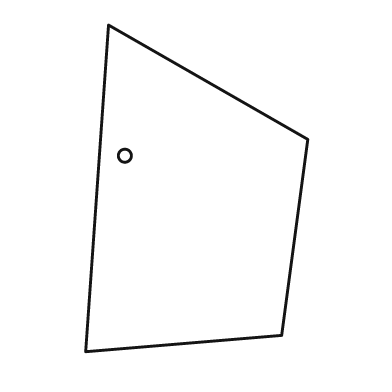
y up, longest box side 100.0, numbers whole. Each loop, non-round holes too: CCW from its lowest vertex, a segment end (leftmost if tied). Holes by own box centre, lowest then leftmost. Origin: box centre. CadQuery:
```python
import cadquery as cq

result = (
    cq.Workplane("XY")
    .moveTo(-34.0, -50.0)
    .lineTo(26.0, -45.0)
    .lineTo(34.0, 15.0)
    .lineTo(-27.0, 50.0)
    .close()
    .moveTo(-22.0, 10.0)
    .circle(2.0)
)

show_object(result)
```